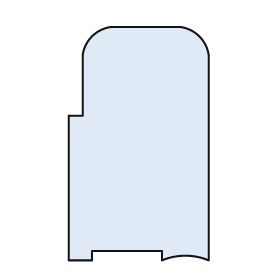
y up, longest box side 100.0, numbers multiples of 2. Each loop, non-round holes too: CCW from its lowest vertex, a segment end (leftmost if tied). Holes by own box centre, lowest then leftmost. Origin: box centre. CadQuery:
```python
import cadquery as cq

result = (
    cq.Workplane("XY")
    .moveTo(-30.0, -50.0)
    .lineTo(-20.0, -50.0)
    .lineTo(-20.0, -46.0)
    .lineTo(10.0, -46.0)
    .lineTo(10.0, -50.0)
    .threePointArc((20.0, -48.0), (30.0, -50.0))
    .lineTo(30.0, 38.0)
    .threePointArc((26.0, 46.0), (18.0, 50.0))
    .lineTo(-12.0, 50.0)
    .threePointArc((-20.0, 46.0), (-24.0, 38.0))
    .lineTo(-24.0, 12.0)
    .lineTo(-30.0, 12.0)
    .close()
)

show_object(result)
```